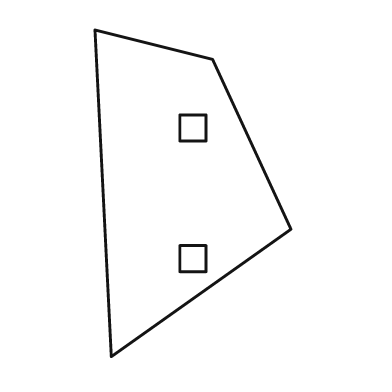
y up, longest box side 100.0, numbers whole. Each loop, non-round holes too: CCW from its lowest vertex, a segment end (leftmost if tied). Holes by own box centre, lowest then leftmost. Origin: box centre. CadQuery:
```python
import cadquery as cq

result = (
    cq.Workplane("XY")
    .moveTo(-25.0, -50.0)
    .lineTo(30.0, -11.0)
    .lineTo(6.0, 41.0)
    .lineTo(-30.0, 50.0)
    .close()
    .moveTo(-4.0, -24.0)
    .lineTo(4.0, -24.0)
    .lineTo(4.0, -16.0)
    .lineTo(-4.0, -16.0)
    .close()
    .moveTo(-4.0, 16.0)
    .lineTo(4.0, 16.0)
    .lineTo(4.0, 24.0)
    .lineTo(-4.0, 24.0)
    .close()
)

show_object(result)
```